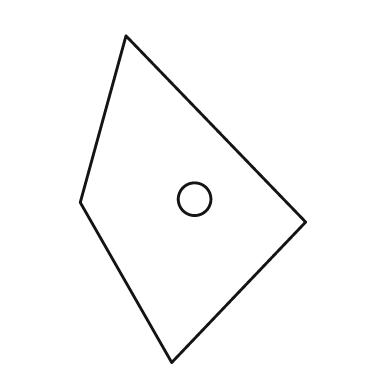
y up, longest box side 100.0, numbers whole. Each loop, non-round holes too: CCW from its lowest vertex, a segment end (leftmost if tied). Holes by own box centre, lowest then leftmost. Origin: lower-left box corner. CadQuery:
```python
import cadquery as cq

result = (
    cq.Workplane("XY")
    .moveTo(28.0, 0.0)
    .lineTo(69.0, 43.0)
    .lineTo(14.0, 100.0)
    .lineTo(0.0, 49.0)
    .close()
    .moveTo(35.0, 50.0)
    .circle(5.0)
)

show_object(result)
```